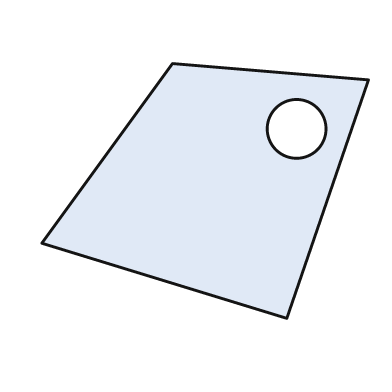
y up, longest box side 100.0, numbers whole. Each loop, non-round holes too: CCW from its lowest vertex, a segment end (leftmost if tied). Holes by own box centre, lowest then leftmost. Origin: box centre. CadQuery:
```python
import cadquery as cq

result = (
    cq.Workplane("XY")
    .moveTo(25.0, -39.0)
    .lineTo(50.0, 34.0)
    .lineTo(-10.0, 39.0)
    .lineTo(-50.0, -16.0)
    .close()
    .moveTo(28.0, 19.0)
    .circle(9.0)
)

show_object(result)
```